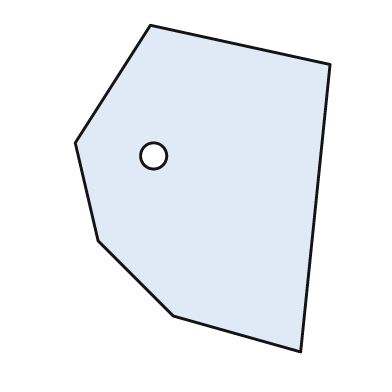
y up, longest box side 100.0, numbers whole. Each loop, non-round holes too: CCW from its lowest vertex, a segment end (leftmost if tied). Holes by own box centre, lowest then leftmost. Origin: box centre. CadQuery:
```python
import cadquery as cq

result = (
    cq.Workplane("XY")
    .moveTo(30.0, -50.0)
    .lineTo(39.0, 38.0)
    .lineTo(-16.0, 50.0)
    .lineTo(-39.0, 14.0)
    .lineTo(-32.0, -16.0)
    .lineTo(-9.0, -39.0)
    .close()
    .moveTo(-15.0, 10.0)
    .circle(4.0)
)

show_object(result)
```